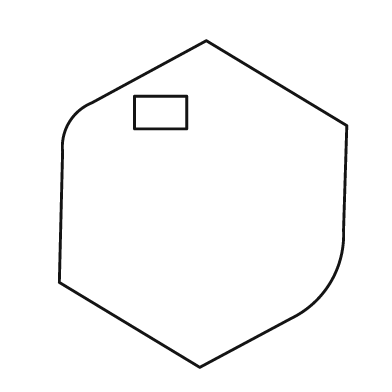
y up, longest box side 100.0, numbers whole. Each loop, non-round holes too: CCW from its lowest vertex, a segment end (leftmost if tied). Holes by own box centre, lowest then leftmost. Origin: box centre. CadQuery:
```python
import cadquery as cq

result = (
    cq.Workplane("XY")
    .moveTo(-1.0, -50.0)
    .lineTo(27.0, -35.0)
    .threePointArc((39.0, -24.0), (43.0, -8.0))
    .lineTo(44.0, 24.0)
    .lineTo(1.0, 50.0)
    .lineTo(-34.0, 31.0)
    .threePointArc((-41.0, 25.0), (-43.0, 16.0))
    .lineTo(-44.0, -24.0)
    .close()
    .moveTo(-21.0, 23.0)
    .lineTo(-5.0, 23.0)
    .lineTo(-5.0, 33.0)
    .lineTo(-21.0, 33.0)
    .close()
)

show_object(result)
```